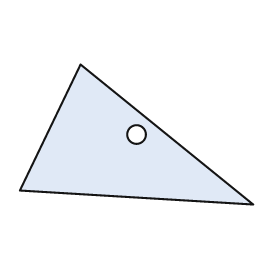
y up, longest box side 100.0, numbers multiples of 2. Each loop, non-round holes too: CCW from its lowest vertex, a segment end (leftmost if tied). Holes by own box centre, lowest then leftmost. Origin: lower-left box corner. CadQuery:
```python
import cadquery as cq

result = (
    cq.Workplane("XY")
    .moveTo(100.0, 0.0)
    .lineTo(26.0, 60.0)
    .lineTo(0.0, 6.0)
    .close()
    .moveTo(50.0, 30.0)
    .circle(4.0)
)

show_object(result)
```